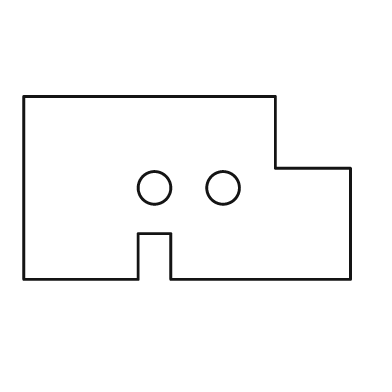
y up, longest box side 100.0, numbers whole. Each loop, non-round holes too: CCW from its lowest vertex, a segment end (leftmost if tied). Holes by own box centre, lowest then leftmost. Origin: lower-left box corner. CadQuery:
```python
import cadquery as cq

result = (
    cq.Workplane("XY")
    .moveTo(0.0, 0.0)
    .lineTo(35.0, 0.0)
    .lineTo(35.0, 14.0)
    .lineTo(45.0, 14.0)
    .lineTo(45.0, 0.0)
    .lineTo(100.0, 0.0)
    .lineTo(100.0, 34.0)
    .lineTo(77.0, 34.0)
    .lineTo(77.0, 56.0)
    .lineTo(0.0, 56.0)
    .close()
    .moveTo(40.0, 28.0)
    .circle(5.0)
    .moveTo(61.0, 28.0)
    .circle(5.0)
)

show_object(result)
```